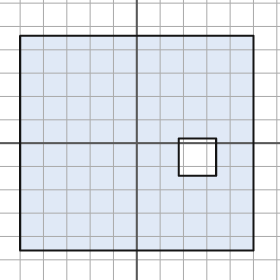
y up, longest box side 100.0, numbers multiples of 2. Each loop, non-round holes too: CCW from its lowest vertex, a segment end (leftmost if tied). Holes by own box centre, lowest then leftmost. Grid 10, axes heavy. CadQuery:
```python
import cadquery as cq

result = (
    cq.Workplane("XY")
    .moveTo(-50.0, -46.0)
    .lineTo(50.0, -46.0)
    .lineTo(50.0, 46.0)
    .lineTo(-50.0, 46.0)
    .close()
    .moveTo(18.0, -14.0)
    .lineTo(34.0, -14.0)
    .lineTo(34.0, 2.0)
    .lineTo(18.0, 2.0)
    .close()
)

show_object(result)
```